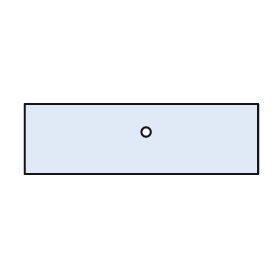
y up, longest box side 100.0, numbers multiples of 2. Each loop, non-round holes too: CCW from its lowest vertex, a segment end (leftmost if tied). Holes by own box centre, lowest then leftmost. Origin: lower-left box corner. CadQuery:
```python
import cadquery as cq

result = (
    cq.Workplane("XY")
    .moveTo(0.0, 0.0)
    .lineTo(100.0, 0.0)
    .lineTo(100.0, 30.0)
    .lineTo(0.0, 30.0)
    .close()
    .moveTo(52.0, 18.0)
    .circle(2.0)
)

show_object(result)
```